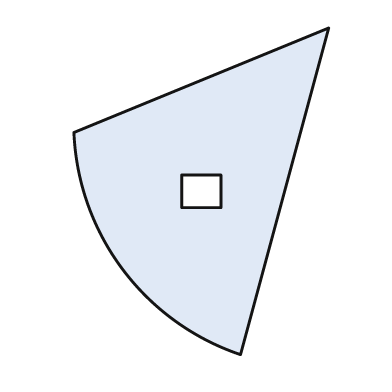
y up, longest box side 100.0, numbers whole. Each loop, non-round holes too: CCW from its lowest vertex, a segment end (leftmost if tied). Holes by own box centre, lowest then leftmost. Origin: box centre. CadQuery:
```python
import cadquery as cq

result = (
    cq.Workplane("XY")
    .moveTo(12.0, -50.0)
    .lineTo(39.0, 50.0)
    .lineTo(-39.0, 18.0)
    .threePointArc((-24.0, -24.0), (12.0, -50.0))
    .close()
    .moveTo(-6.0, -5.0)
    .lineTo(6.0, -5.0)
    .lineTo(6.0, 5.0)
    .lineTo(-6.0, 5.0)
    .close()
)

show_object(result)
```